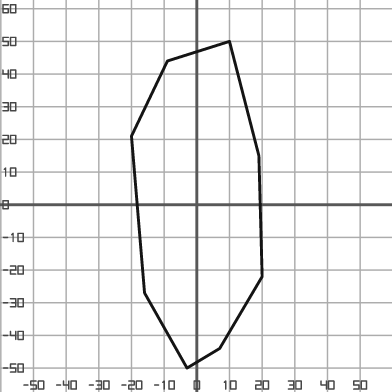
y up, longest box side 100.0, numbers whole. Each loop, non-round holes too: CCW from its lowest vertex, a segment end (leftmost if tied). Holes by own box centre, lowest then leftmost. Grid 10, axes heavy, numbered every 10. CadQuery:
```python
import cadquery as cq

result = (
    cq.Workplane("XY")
    .moveTo(-3.0, -50.0)
    .lineTo(7.0, -44.0)
    .lineTo(20.0, -22.0)
    .lineTo(19.0, 15.0)
    .lineTo(10.0, 50.0)
    .lineTo(-9.0, 44.0)
    .lineTo(-20.0, 21.0)
    .lineTo(-16.0, -27.0)
    .close()
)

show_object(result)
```